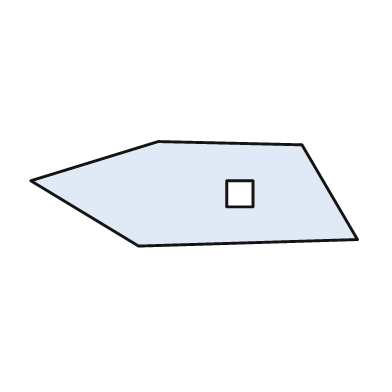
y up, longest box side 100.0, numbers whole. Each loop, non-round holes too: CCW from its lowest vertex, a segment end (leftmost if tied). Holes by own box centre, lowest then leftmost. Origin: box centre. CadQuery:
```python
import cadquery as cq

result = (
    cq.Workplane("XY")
    .moveTo(-17.0, -16.0)
    .lineTo(50.0, -14.0)
    .lineTo(33.0, 15.0)
    .lineTo(-11.0, 16.0)
    .lineTo(-50.0, 4.0)
    .close()
    .moveTo(10.0, -4.0)
    .lineTo(18.0, -4.0)
    .lineTo(18.0, 4.0)
    .lineTo(10.0, 4.0)
    .close()
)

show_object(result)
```